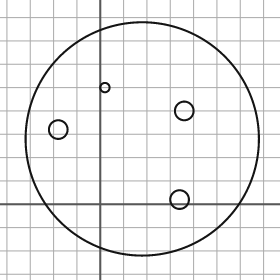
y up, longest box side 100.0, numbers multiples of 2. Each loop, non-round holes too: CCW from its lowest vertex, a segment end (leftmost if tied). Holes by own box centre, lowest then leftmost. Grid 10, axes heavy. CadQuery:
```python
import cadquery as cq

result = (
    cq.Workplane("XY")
    .moveTo(18.0, 28.0)
    .circle(50.0)
    .moveTo(34.0, 2.0)
    .circle(4.0)
    .moveTo(-18.0, 32.0)
    .circle(4.0)
    .moveTo(36.0, 40.0)
    .circle(4.0)
    .moveTo(2.0, 50.0)
    .circle(2.0)
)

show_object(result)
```